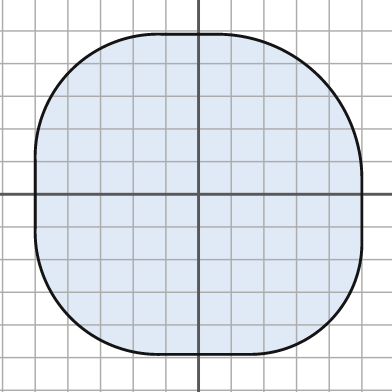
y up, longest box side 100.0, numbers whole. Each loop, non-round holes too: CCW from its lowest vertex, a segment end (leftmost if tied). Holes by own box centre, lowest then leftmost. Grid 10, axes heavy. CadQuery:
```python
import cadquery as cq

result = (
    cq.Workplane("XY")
    .moveTo(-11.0, -49.0)
    .lineTo(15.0, -49.0)
    .threePointArc((40.0, -39.0), (50.0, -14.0))
    .lineTo(50.0, 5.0)
    .threePointArc((37.0, 36.0), (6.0, 49.0))
    .lineTo(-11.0, 49.0)
    .threePointArc((-39.0, 38.0), (-50.0, 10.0))
    .lineTo(-50.0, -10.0)
    .threePointArc((-39.0, -38.0), (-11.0, -49.0))
    .close()
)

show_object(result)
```